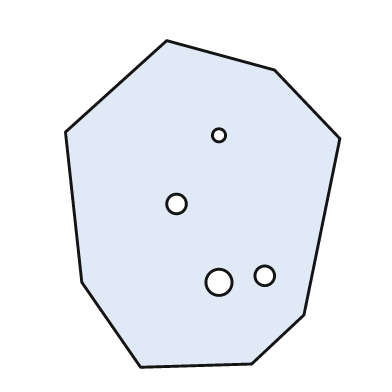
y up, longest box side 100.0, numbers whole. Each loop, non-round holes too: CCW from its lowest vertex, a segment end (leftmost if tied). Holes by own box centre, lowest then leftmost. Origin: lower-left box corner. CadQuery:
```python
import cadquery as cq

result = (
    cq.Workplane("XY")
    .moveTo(23.0, 0.0)
    .lineTo(57.0, 1.0)
    .lineTo(73.0, 16.0)
    .lineTo(84.0, 70.0)
    .lineTo(64.0, 91.0)
    .lineTo(31.0, 100.0)
    .lineTo(0.0, 72.0)
    .lineTo(5.0, 26.0)
    .close()
    .moveTo(47.0, 26.0)
    .circle(4.0)
    .moveTo(61.0, 28.0)
    .circle(3.0)
    .moveTo(34.0, 50.0)
    .circle(3.0)
    .moveTo(47.0, 71.0)
    .circle(2.0)
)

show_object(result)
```